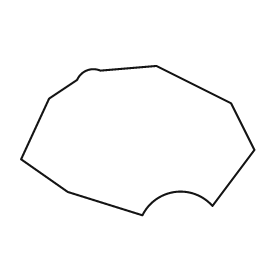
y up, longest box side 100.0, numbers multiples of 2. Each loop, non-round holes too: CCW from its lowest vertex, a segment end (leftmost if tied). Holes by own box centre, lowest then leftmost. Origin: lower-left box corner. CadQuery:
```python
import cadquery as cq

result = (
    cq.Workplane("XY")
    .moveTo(52.0, 0.0)
    .threePointArc((66.0, 10.0), (82.0, 4.0))
    .lineTo(100.0, 28.0)
    .lineTo(90.0, 48.0)
    .lineTo(58.0, 64.0)
    .lineTo(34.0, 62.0)
    .threePointArc((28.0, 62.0), (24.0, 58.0))
    .lineTo(12.0, 50.0)
    .lineTo(0.0, 24.0)
    .lineTo(20.0, 10.0)
    .close()
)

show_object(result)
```